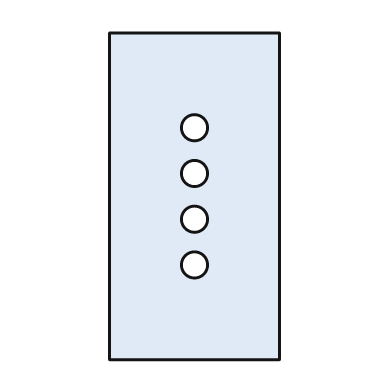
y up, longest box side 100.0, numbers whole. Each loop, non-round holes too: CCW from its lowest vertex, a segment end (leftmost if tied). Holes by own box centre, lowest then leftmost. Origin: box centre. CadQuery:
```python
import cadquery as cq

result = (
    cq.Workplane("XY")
    .moveTo(-26.0, -50.0)
    .lineTo(26.0, -50.0)
    .lineTo(26.0, 50.0)
    .lineTo(-26.0, 50.0)
    .close()
    .moveTo(0.0, -21.0)
    .circle(4.0)
    .moveTo(0.0, -7.0)
    .circle(4.0)
    .moveTo(0.0, 7.0)
    .circle(4.0)
    .moveTo(0.0, 21.0)
    .circle(4.0)
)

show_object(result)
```